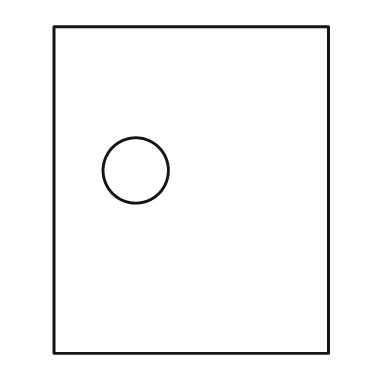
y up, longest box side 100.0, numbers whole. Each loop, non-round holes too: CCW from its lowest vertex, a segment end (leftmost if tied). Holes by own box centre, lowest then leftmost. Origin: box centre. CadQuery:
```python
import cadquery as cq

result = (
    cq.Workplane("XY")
    .moveTo(-42.0, -50.0)
    .lineTo(42.0, -50.0)
    .lineTo(42.0, 50.0)
    .lineTo(-42.0, 50.0)
    .close()
    .moveTo(-17.0, 6.0)
    .circle(10.0)
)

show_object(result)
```